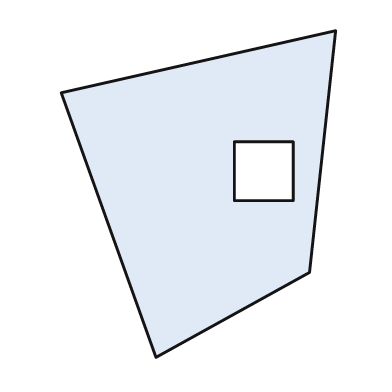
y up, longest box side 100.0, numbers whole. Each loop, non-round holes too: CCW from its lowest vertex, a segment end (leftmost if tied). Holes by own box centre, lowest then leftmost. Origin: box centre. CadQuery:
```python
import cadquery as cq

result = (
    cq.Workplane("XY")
    .moveTo(-13.0, -50.0)
    .lineTo(34.0, -24.0)
    .lineTo(42.0, 50.0)
    .lineTo(-42.0, 31.0)
    .close()
    .moveTo(11.0, -2.0)
    .lineTo(29.0, -2.0)
    .lineTo(29.0, 16.0)
    .lineTo(11.0, 16.0)
    .close()
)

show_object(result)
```